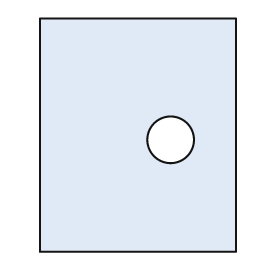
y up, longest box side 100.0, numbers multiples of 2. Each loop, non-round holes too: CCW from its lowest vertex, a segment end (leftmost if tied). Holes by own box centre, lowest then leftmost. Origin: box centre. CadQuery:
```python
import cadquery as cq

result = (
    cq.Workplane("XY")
    .moveTo(-42.0, -50.0)
    .lineTo(42.0, -50.0)
    .lineTo(42.0, 50.0)
    .lineTo(-42.0, 50.0)
    .close()
    .moveTo(14.0, -2.0)
    .circle(10.0)
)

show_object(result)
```